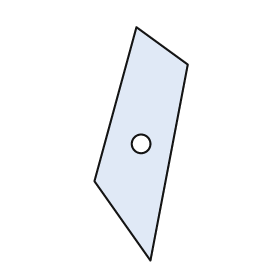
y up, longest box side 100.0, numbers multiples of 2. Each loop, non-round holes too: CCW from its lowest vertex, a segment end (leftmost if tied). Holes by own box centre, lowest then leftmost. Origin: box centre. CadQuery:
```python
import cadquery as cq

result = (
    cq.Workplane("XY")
    .moveTo(4.0, -50.0)
    .lineTo(20.0, 34.0)
    .lineTo(-2.0, 50.0)
    .lineTo(-20.0, -16.0)
    .close()
    .moveTo(0.0, 0.0)
    .circle(4.0)
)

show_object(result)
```